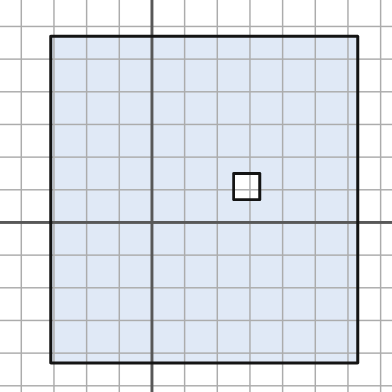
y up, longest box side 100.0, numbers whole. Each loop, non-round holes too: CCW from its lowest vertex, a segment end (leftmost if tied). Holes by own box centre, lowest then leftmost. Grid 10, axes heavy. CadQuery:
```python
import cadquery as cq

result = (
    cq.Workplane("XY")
    .moveTo(-31.0, -43.0)
    .lineTo(63.0, -43.0)
    .lineTo(63.0, 57.0)
    .lineTo(-31.0, 57.0)
    .close()
    .moveTo(25.0, 7.0)
    .lineTo(33.0, 7.0)
    .lineTo(33.0, 15.0)
    .lineTo(25.0, 15.0)
    .close()
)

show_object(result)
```